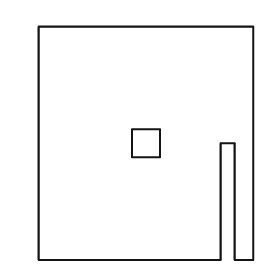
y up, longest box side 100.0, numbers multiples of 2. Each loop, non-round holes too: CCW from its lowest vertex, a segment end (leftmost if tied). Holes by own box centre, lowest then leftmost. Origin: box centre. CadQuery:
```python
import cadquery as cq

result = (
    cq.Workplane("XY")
    .moveTo(-46.0, -50.0)
    .lineTo(32.0, -50.0)
    .lineTo(32.0, 0.0)
    .lineTo(38.0, 0.0)
    .lineTo(38.0, -50.0)
    .lineTo(46.0, -50.0)
    .lineTo(46.0, 50.0)
    .lineTo(-46.0, 50.0)
    .close()
    .moveTo(-6.0, -6.0)
    .lineTo(6.0, -6.0)
    .lineTo(6.0, 6.0)
    .lineTo(-6.0, 6.0)
    .close()
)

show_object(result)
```